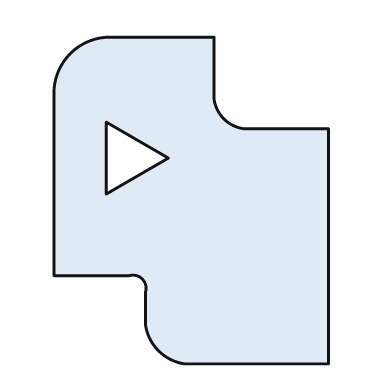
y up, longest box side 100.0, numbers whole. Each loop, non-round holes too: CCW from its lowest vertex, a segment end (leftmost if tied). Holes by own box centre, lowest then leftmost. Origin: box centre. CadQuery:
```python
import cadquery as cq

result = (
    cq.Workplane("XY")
    .moveTo(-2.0, -50.0)
    .lineTo(42.0, -50.0)
    .lineTo(42.0, 22.0)
    .lineTo(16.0, 22.0)
    .threePointArc((10.0, 25.0), (7.0, 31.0))
    .lineTo(7.0, 50.0)
    .lineTo(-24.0, 50.0)
    .threePointArc((-37.0, 45.0), (-42.0, 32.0))
    .lineTo(-42.0, -23.0)
    .lineTo(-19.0, -23.0)
    .threePointArc((-15.0, -24.0), (-14.0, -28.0))
    .lineTo(-14.0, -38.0)
    .threePointArc((-10.0, -46.0), (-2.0, -50.0))
    .close()
    .moveTo(-26.0, 2.0)
    .lineTo(-7.0, 13.0)
    .lineTo(-26.0, 24.0)
    .close()
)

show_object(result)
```